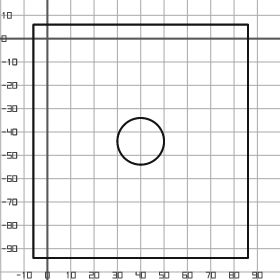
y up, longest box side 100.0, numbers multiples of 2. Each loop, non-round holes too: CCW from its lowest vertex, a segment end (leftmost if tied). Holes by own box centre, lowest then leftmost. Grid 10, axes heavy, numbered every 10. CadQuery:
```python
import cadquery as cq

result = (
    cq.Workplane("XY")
    .moveTo(-6.0, -94.0)
    .lineTo(86.0, -94.0)
    .lineTo(86.0, 6.0)
    .lineTo(-6.0, 6.0)
    .close()
    .moveTo(40.0, -44.0)
    .circle(10.0)
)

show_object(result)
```